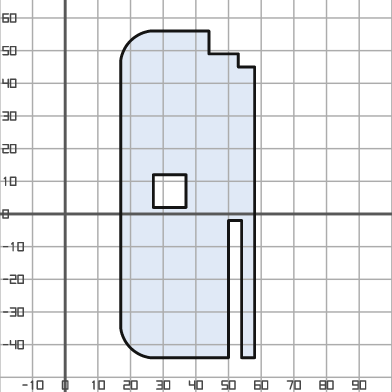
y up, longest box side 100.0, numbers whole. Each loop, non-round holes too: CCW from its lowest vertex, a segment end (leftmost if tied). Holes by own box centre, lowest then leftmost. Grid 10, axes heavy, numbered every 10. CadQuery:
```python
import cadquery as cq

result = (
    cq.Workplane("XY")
    .moveTo(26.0, -44.0)
    .lineTo(50.0, -44.0)
    .lineTo(50.0, -2.0)
    .lineTo(54.0, -2.0)
    .lineTo(54.0, -44.0)
    .lineTo(58.0, -44.0)
    .lineTo(58.0, 45.0)
    .lineTo(53.0, 45.0)
    .lineTo(53.0, 49.0)
    .lineTo(44.0, 49.0)
    .lineTo(44.0, 56.0)
    .lineTo(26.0, 56.0)
    .threePointArc((20.0, 53.0), (17.0, 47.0))
    .lineTo(17.0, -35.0)
    .threePointArc((20.0, -41.0), (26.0, -44.0))
    .close()
    .moveTo(27.0, 2.0)
    .lineTo(37.0, 2.0)
    .lineTo(37.0, 12.0)
    .lineTo(27.0, 12.0)
    .close()
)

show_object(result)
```